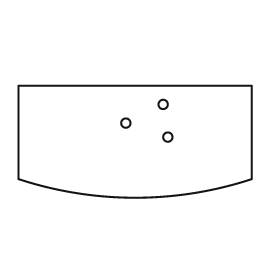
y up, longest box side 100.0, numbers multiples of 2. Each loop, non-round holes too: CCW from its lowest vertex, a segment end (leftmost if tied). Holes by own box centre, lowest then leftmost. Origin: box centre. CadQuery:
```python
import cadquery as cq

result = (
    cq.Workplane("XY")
    .moveTo(-50.0, -16.0)
    .threePointArc((0.0, -24.0), (50.0, -16.0))
    .lineTo(50.0, 24.0)
    .lineTo(-50.0, 24.0)
    .close()
    .moveTo(14.0, 2.0)
    .circle(2.0)
    .moveTo(-4.0, 8.0)
    .circle(2.0)
    .moveTo(12.0, 16.0)
    .circle(2.0)
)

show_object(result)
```